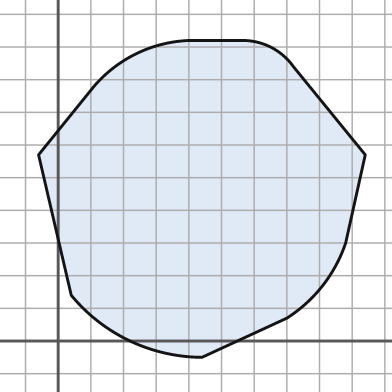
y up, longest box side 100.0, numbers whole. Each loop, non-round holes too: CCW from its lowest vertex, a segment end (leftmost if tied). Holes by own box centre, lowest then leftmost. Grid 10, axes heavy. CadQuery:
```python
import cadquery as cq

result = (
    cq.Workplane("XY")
    .moveTo(44.0, -5.0)
    .lineTo(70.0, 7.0)
    .threePointArc((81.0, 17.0), (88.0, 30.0))
    .lineTo(94.0, 57.0)
    .lineTo(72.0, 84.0)
    .threePointArc((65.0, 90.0), (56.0, 92.0))
    .lineTo(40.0, 92.0)
    .threePointArc((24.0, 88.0), (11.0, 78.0))
    .lineTo(-6.0, 57.0)
    .lineTo(4.0, 14.0)
    .threePointArc((22.0, 0.0), (44.0, -5.0))
    .close()
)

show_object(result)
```